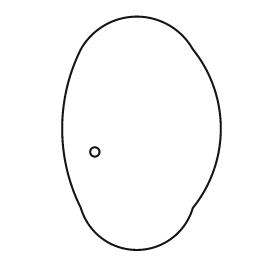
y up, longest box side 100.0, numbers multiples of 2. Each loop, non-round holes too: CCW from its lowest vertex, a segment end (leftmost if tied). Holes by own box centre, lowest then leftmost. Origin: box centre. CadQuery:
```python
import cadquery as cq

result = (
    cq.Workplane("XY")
    .moveTo(-26.0, -32.0)
    .threePointArc((-2.0, -50.0), (22.0, -32.0))
    .threePointArc((34.0, 2.0), (22.0, 36.0))
    .threePointArc((-2.0, 50.0), (-26.0, 36.0))
    .threePointArc((-34.0, 2.0), (-26.0, -32.0))
    .close()
    .moveTo(-20.0, -8.0)
    .circle(2.0)
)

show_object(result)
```